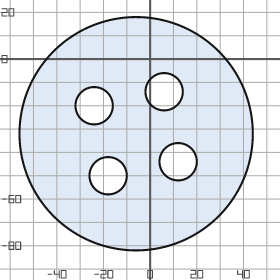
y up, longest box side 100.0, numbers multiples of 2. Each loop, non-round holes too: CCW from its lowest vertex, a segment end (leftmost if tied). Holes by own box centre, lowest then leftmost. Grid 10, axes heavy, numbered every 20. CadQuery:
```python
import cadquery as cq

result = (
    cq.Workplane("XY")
    .moveTo(-6.0, -32.0)
    .circle(50.0)
    .moveTo(-18.0, -50.0)
    .circle(8.0)
    .moveTo(12.0, -44.0)
    .circle(8.0)
    .moveTo(-24.0, -20.0)
    .circle(8.0)
    .moveTo(6.0, -14.0)
    .circle(8.0)
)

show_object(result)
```